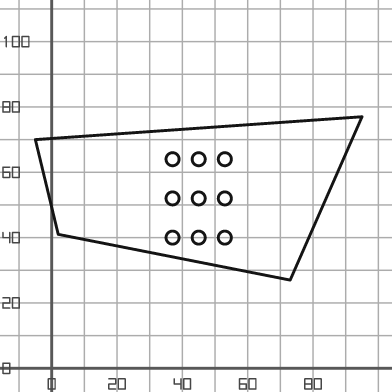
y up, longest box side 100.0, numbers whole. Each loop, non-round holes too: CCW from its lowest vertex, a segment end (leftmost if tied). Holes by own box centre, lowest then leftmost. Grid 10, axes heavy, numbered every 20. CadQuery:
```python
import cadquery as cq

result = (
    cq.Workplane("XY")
    .moveTo(73.0, 27.0)
    .lineTo(95.0, 77.0)
    .lineTo(-5.0, 70.0)
    .lineTo(2.0, 41.0)
    .close()
    .moveTo(37.0, 40.0)
    .circle(2.0)
    .moveTo(45.0, 40.0)
    .circle(2.0)
    .moveTo(53.0, 40.0)
    .circle(2.0)
    .moveTo(37.0, 52.0)
    .circle(2.0)
    .moveTo(45.0, 52.0)
    .circle(2.0)
    .moveTo(53.0, 52.0)
    .circle(2.0)
    .moveTo(37.0, 64.0)
    .circle(2.0)
    .moveTo(45.0, 64.0)
    .circle(2.0)
    .moveTo(53.0, 64.0)
    .circle(2.0)
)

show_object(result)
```